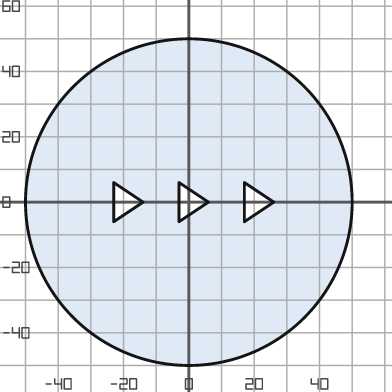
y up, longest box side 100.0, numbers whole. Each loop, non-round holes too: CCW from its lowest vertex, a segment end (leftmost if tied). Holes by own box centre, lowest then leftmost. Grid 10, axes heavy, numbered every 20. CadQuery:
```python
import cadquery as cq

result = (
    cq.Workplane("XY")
    .moveTo(0.0, 0.0)
    .circle(50.0)
    .moveTo(-23.0, -6.0)
    .lineTo(-14.0, 0.0)
    .lineTo(-23.0, 6.0)
    .close()
    .moveTo(-3.0, -6.0)
    .lineTo(6.0, 0.0)
    .lineTo(-3.0, 6.0)
    .close()
    .moveTo(17.0, -6.0)
    .lineTo(26.0, 0.0)
    .lineTo(17.0, 6.0)
    .close()
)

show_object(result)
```